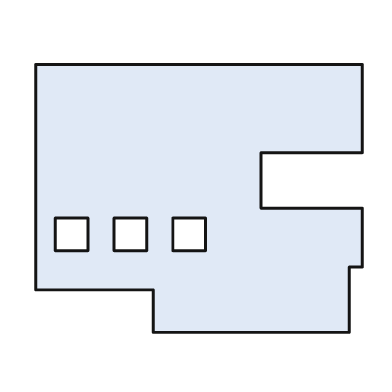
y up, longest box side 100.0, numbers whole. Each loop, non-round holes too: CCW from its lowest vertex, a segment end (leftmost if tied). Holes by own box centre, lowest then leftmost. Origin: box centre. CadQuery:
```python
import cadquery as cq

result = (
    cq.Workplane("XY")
    .moveTo(-14.0, -41.0)
    .lineTo(46.0, -41.0)
    .lineTo(46.0, -21.0)
    .lineTo(50.0, -21.0)
    .lineTo(50.0, -3.0)
    .lineTo(19.0, -3.0)
    .lineTo(19.0, 14.0)
    .lineTo(50.0, 14.0)
    .lineTo(50.0, 41.0)
    .lineTo(-50.0, 41.0)
    .lineTo(-50.0, -28.0)
    .lineTo(-14.0, -28.0)
    .close()
    .moveTo(-44.0, -16.0)
    .lineTo(-34.0, -16.0)
    .lineTo(-34.0, -6.0)
    .lineTo(-44.0, -6.0)
    .close()
    .moveTo(-26.0, -16.0)
    .lineTo(-16.0, -16.0)
    .lineTo(-16.0, -6.0)
    .lineTo(-26.0, -6.0)
    .close()
    .moveTo(-8.0, -16.0)
    .lineTo(2.0, -16.0)
    .lineTo(2.0, -6.0)
    .lineTo(-8.0, -6.0)
    .close()
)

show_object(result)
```